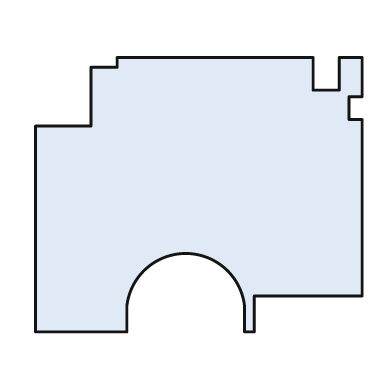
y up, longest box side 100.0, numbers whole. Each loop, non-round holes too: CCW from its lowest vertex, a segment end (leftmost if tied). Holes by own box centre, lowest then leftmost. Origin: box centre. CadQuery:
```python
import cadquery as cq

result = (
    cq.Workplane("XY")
    .moveTo(-50.0, -42.0)
    .lineTo(-22.0, -42.0)
    .lineTo(-22.0, -34.0)
    .threePointArc((-4.0, -18.0), (14.0, -34.0))
    .lineTo(14.0, -42.0)
    .lineTo(17.0, -42.0)
    .lineTo(17.0, -31.0)
    .lineTo(50.0, -31.0)
    .lineTo(50.0, 23.0)
    .lineTo(46.0, 23.0)
    .lineTo(46.0, 30.0)
    .lineTo(50.0, 30.0)
    .lineTo(50.0, 42.0)
    .lineTo(43.0, 42.0)
    .lineTo(43.0, 32.0)
    .lineTo(35.0, 32.0)
    .lineTo(35.0, 42.0)
    .lineTo(-25.0, 42.0)
    .lineTo(-25.0, 39.0)
    .lineTo(-33.0, 39.0)
    .lineTo(-33.0, 21.0)
    .lineTo(-50.0, 21.0)
    .close()
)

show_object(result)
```